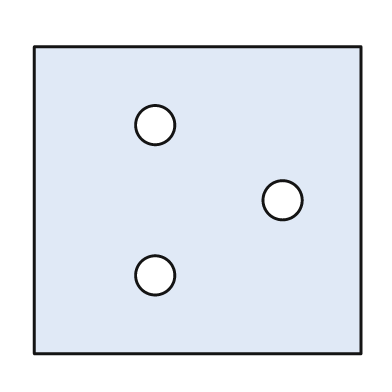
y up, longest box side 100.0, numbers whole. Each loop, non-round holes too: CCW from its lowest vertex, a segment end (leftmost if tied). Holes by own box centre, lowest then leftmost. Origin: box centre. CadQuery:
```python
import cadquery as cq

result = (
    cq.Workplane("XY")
    .moveTo(-50.0, -47.0)
    .lineTo(50.0, -47.0)
    .lineTo(50.0, 47.0)
    .lineTo(-50.0, 47.0)
    .close()
    .moveTo(-13.0, -23.0)
    .circle(6.0)
    .moveTo(26.0, 0.0)
    .circle(6.0)
    .moveTo(-13.0, 23.0)
    .circle(6.0)
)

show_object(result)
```